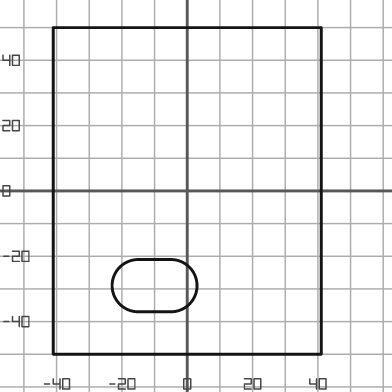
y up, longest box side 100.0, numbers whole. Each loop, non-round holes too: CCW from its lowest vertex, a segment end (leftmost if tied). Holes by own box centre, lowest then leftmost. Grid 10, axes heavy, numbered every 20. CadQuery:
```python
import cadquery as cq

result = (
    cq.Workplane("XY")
    .moveTo(-41.0, -50.0)
    .lineTo(41.0, -50.0)
    .lineTo(41.0, 50.0)
    .lineTo(-41.0, 50.0)
    .close()
    .moveTo(-15.0, -37.0)
    .lineTo(-5.0, -37.0)
    .threePointArc((3.0, -29.0), (-5.0, -21.0))
    .lineTo(-15.0, -21.0)
    .threePointArc((-23.0, -29.0), (-15.0, -37.0))
    .close()
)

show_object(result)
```